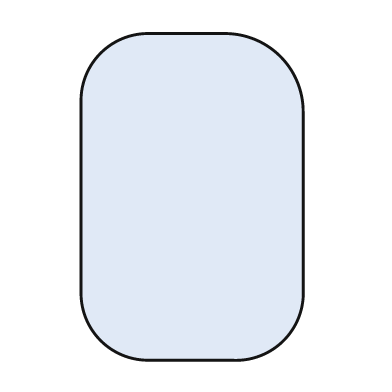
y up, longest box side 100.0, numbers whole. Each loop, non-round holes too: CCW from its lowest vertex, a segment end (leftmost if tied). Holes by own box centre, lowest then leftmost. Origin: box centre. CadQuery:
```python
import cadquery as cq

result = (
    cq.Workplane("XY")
    .moveTo(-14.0, -50.0)
    .lineTo(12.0, -50.0)
    .threePointArc((28.0, -44.0), (34.0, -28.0))
    .lineTo(34.0, 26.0)
    .threePointArc((27.0, 43.0), (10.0, 50.0))
    .lineTo(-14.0, 50.0)
    .threePointArc((-28.0, 44.0), (-34.0, 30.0))
    .lineTo(-34.0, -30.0)
    .threePointArc((-28.0, -44.0), (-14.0, -50.0))
    .close()
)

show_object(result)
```